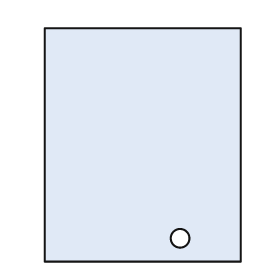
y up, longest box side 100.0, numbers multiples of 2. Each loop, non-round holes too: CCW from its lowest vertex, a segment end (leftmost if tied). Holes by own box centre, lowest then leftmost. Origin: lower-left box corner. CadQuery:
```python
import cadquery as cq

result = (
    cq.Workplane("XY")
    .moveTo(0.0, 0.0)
    .lineTo(84.0, 0.0)
    .lineTo(84.0, 100.0)
    .lineTo(0.0, 100.0)
    .close()
    .moveTo(58.0, 10.0)
    .circle(4.0)
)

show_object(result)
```